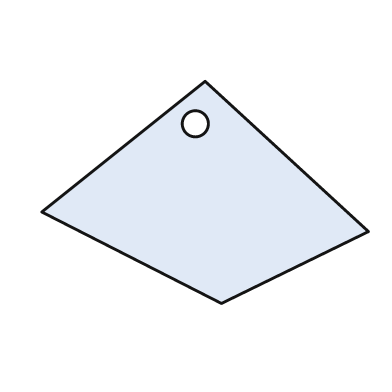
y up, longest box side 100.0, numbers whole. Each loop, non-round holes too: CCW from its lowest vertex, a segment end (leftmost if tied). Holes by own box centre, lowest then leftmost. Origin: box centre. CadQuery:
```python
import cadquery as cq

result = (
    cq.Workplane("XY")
    .moveTo(5.0, -34.0)
    .lineTo(50.0, -12.0)
    .lineTo(0.0, 34.0)
    .lineTo(-50.0, -6.0)
    .close()
    .moveTo(-3.0, 21.0)
    .circle(4.0)
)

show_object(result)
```